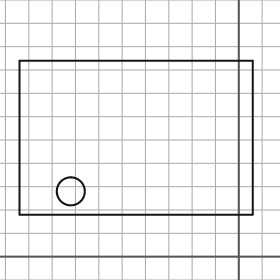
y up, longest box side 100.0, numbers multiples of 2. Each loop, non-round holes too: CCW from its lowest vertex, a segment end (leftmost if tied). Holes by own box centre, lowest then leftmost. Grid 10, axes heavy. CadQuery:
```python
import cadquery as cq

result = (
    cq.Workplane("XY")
    .moveTo(-94.0, 18.0)
    .lineTo(6.0, 18.0)
    .lineTo(6.0, 84.0)
    .lineTo(-94.0, 84.0)
    .close()
    .moveTo(-72.0, 28.0)
    .circle(6.0)
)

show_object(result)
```